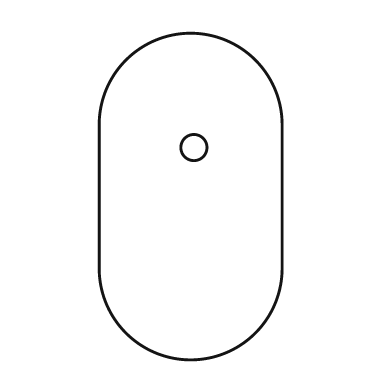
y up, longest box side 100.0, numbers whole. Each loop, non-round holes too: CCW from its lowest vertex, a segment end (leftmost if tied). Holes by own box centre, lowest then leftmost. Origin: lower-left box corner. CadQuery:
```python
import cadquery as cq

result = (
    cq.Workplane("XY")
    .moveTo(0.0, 28.0)
    .threePointArc((28.0, 0.0), (56.0, 28.0))
    .lineTo(56.0, 72.0)
    .threePointArc((28.0, 100.0), (0.0, 72.0))
    .close()
    .moveTo(29.0, 65.0)
    .circle(4.0)
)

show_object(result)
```